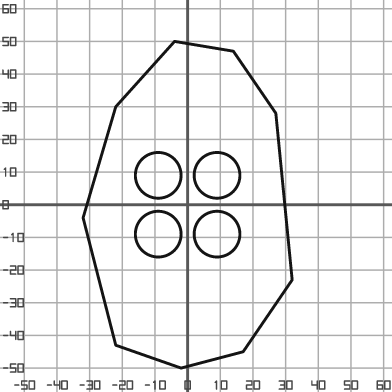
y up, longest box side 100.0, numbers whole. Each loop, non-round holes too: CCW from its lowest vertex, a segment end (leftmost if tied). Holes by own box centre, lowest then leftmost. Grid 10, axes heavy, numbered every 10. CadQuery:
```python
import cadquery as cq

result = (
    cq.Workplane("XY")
    .moveTo(-2.0, -50.0)
    .lineTo(17.0, -45.0)
    .lineTo(32.0, -23.0)
    .lineTo(27.0, 28.0)
    .lineTo(14.0, 47.0)
    .lineTo(-4.0, 50.0)
    .lineTo(-22.0, 30.0)
    .lineTo(-32.0, -4.0)
    .lineTo(-22.0, -43.0)
    .close()
    .moveTo(-9.0, -9.0)
    .circle(7.0)
    .moveTo(9.0, -9.0)
    .circle(7.0)
    .moveTo(-9.0, 9.0)
    .circle(7.0)
    .moveTo(9.0, 9.0)
    .circle(7.0)
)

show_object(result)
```